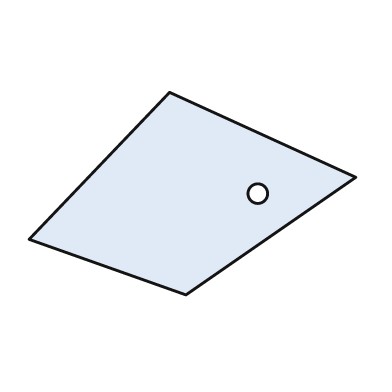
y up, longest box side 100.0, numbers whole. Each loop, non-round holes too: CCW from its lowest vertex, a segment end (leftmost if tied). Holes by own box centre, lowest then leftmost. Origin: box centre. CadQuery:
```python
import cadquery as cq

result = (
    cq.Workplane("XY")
    .moveTo(-2.0, -31.0)
    .lineTo(50.0, 5.0)
    .lineTo(-7.0, 31.0)
    .lineTo(-50.0, -14.0)
    .close()
    .moveTo(20.0, 0.0)
    .circle(3.0)
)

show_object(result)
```